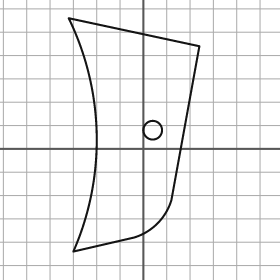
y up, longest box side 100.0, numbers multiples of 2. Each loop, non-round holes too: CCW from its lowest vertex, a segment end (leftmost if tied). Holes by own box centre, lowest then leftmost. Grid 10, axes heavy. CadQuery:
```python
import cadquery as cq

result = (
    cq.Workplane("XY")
    .moveTo(-30.0, -44.0)
    .lineTo(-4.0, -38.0)
    .threePointArc((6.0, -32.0), (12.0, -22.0))
    .lineTo(24.0, 44.0)
    .lineTo(-32.0, 56.0)
    .threePointArc((-20.0, 6.0), (-30.0, -44.0))
    .close()
    .moveTo(4.0, 8.0)
    .circle(4.0)
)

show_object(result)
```